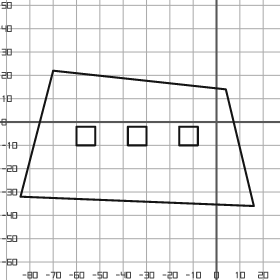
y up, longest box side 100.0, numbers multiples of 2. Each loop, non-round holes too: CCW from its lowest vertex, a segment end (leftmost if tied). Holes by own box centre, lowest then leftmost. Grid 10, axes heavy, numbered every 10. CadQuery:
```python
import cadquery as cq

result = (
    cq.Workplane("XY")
    .moveTo(16.0, -36.0)
    .lineTo(4.0, 14.0)
    .lineTo(-70.0, 22.0)
    .lineTo(-84.0, -32.0)
    .close()
    .moveTo(-60.0, -10.0)
    .lineTo(-52.0, -10.0)
    .lineTo(-52.0, -2.0)
    .lineTo(-60.0, -2.0)
    .close()
    .moveTo(-38.0, -10.0)
    .lineTo(-30.0, -10.0)
    .lineTo(-30.0, -2.0)
    .lineTo(-38.0, -2.0)
    .close()
    .moveTo(-16.0, -10.0)
    .lineTo(-8.0, -10.0)
    .lineTo(-8.0, -2.0)
    .lineTo(-16.0, -2.0)
    .close()
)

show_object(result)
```